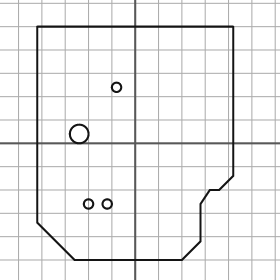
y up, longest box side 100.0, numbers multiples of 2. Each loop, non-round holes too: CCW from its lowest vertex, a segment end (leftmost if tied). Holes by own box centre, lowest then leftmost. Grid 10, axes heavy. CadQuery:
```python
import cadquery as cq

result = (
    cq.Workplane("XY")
    .moveTo(-26.0, -50.0)
    .lineTo(20.0, -50.0)
    .lineTo(28.0, -42.0)
    .lineTo(28.0, -26.0)
    .lineTo(32.0, -20.0)
    .lineTo(36.0, -20.0)
    .lineTo(42.0, -14.0)
    .lineTo(42.0, 50.0)
    .lineTo(-42.0, 50.0)
    .lineTo(-42.0, -34.0)
    .close()
    .moveTo(-20.0, -26.0)
    .circle(2.0)
    .moveTo(-12.0, -26.0)
    .circle(2.0)
    .moveTo(-24.0, 4.0)
    .circle(4.0)
    .moveTo(-8.0, 24.0)
    .circle(2.0)
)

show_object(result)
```